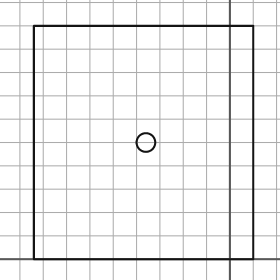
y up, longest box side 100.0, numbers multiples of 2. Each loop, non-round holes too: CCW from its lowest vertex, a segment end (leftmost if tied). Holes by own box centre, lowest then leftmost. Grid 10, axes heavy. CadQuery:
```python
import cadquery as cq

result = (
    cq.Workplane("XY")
    .moveTo(-84.0, 0.0)
    .lineTo(10.0, 0.0)
    .lineTo(10.0, 100.0)
    .lineTo(-84.0, 100.0)
    .close()
    .moveTo(-36.0, 50.0)
    .circle(4.0)
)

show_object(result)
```